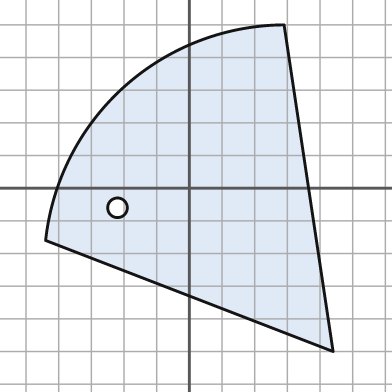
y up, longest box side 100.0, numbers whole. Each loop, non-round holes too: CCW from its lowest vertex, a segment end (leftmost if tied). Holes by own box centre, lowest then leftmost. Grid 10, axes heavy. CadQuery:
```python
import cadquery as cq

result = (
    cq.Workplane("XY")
    .moveTo(44.0, -50.0)
    .lineTo(29.0, 50.0)
    .threePointArc((-20.0, 31.0), (-44.0, -16.0))
    .close()
    .moveTo(-22.0, -6.0)
    .circle(3.0)
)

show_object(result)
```